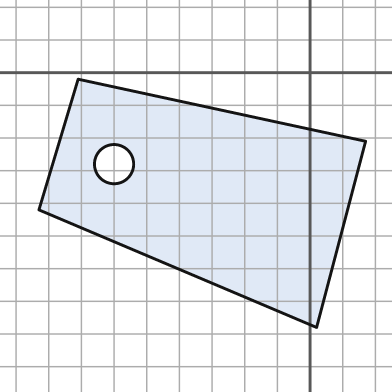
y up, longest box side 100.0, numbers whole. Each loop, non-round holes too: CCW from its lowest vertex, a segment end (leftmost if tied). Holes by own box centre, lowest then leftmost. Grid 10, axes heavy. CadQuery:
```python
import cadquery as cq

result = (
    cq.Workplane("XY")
    .moveTo(2.0, -78.0)
    .lineTo(17.0, -21.0)
    .lineTo(-71.0, -2.0)
    .lineTo(-83.0, -42.0)
    .close()
    .moveTo(-60.0, -28.0)
    .circle(6.0)
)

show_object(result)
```